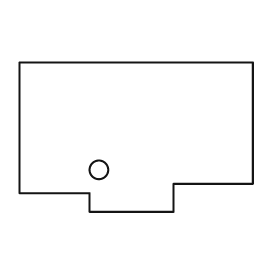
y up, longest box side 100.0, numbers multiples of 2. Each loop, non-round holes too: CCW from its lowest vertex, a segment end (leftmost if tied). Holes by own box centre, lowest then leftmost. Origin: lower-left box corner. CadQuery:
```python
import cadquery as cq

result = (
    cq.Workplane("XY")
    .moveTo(30.0, 0.0)
    .lineTo(66.0, 0.0)
    .lineTo(66.0, 12.0)
    .lineTo(100.0, 12.0)
    .lineTo(100.0, 64.0)
    .lineTo(0.0, 64.0)
    .lineTo(0.0, 8.0)
    .lineTo(30.0, 8.0)
    .close()
    .moveTo(34.0, 18.0)
    .circle(4.0)
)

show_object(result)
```